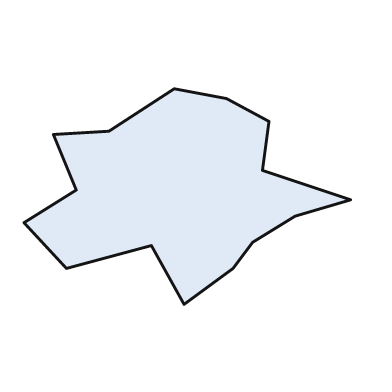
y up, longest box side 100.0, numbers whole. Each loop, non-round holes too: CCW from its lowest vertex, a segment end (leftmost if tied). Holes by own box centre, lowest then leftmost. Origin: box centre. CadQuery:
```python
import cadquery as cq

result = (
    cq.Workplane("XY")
    .moveTo(-1.0, -33.0)
    .lineTo(14.0, -22.0)
    .lineTo(20.0, -14.0)
    .lineTo(33.0, -6.0)
    .lineTo(50.0, -1.0)
    .lineTo(23.0, 8.0)
    .lineTo(25.0, 23.0)
    .lineTo(12.0, 30.0)
    .lineTo(-4.0, 33.0)
    .lineTo(-24.0, 20.0)
    .lineTo(-41.0, 19.0)
    .lineTo(-34.0, 2.0)
    .lineTo(-50.0, -8.0)
    .lineTo(-37.0, -22.0)
    .lineTo(-11.0, -15.0)
    .close()
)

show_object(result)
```